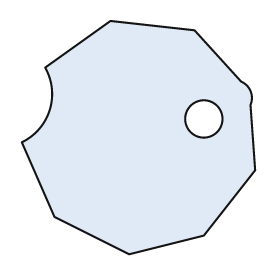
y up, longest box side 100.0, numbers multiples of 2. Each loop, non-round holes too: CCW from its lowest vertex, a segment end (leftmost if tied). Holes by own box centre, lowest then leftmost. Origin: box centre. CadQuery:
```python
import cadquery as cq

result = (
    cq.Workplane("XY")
    .moveTo(-4.0, -50.0)
    .lineTo(28.0, -42.0)
    .lineTo(50.0, -14.0)
    .lineTo(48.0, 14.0)
    .threePointArc((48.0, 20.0), (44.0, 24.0))
    .lineTo(24.0, 46.0)
    .lineTo(-12.0, 50.0)
    .lineTo(-40.0, 30.0)
    .threePointArc((-38.0, 12.0), (-50.0, -2.0))
    .lineTo(-36.0, -34.0)
    .close()
    .moveTo(28.0, 8.0)
    .circle(8.0)
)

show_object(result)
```